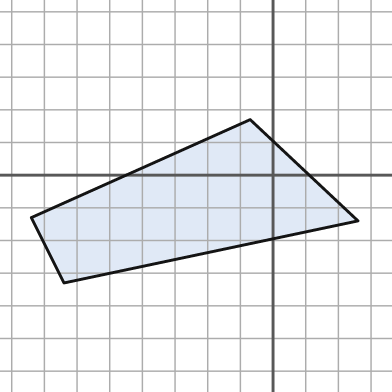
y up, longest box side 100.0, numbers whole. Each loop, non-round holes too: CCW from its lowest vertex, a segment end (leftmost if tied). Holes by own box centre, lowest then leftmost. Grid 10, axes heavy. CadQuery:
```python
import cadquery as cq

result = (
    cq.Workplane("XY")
    .moveTo(-64.0, -33.0)
    .lineTo(26.0, -14.0)
    .lineTo(-7.0, 17.0)
    .lineTo(-74.0, -13.0)
    .close()
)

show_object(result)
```